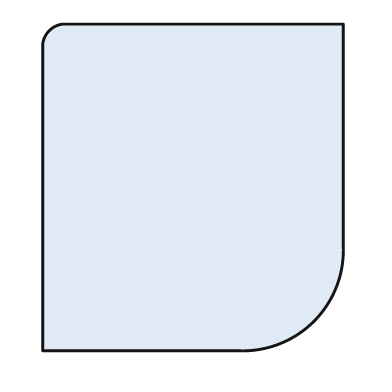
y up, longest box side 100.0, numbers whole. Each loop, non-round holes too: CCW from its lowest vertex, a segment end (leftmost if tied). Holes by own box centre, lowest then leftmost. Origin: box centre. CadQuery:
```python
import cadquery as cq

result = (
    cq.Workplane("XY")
    .moveTo(-46.0, -50.0)
    .lineTo(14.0, -50.0)
    .threePointArc((37.0, -41.0), (46.0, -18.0))
    .lineTo(46.0, 50.0)
    .lineTo(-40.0, 50.0)
    .threePointArc((-44.0, 48.0), (-46.0, 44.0))
    .close()
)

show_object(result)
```